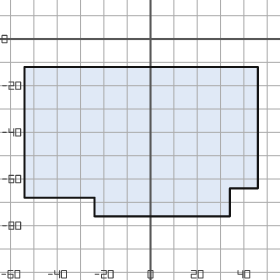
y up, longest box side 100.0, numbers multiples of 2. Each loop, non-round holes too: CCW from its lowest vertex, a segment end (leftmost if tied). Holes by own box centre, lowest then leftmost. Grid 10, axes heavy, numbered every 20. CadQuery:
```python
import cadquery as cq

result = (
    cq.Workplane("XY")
    .moveTo(-24.0, -76.0)
    .lineTo(34.0, -76.0)
    .lineTo(34.0, -64.0)
    .lineTo(46.0, -64.0)
    .lineTo(46.0, -12.0)
    .lineTo(-54.0, -12.0)
    .lineTo(-54.0, -68.0)
    .lineTo(-24.0, -68.0)
    .close()
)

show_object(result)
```